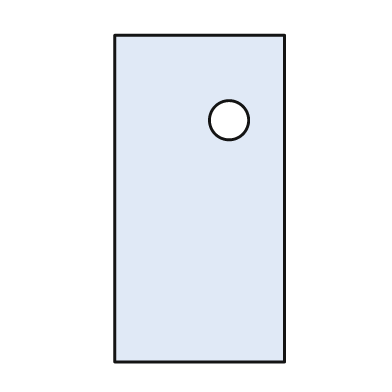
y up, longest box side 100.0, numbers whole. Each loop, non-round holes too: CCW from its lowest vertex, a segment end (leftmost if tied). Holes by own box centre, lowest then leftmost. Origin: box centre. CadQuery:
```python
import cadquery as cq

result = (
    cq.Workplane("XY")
    .moveTo(-26.0, -50.0)
    .lineTo(26.0, -50.0)
    .lineTo(26.0, 50.0)
    .lineTo(-26.0, 50.0)
    .close()
    .moveTo(9.0, 24.0)
    .circle(6.0)
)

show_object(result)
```